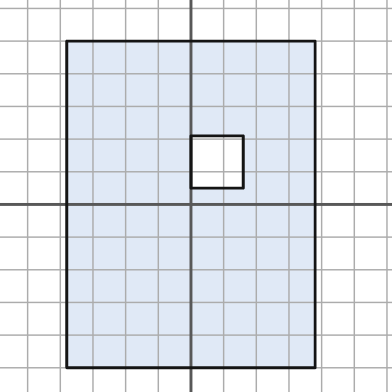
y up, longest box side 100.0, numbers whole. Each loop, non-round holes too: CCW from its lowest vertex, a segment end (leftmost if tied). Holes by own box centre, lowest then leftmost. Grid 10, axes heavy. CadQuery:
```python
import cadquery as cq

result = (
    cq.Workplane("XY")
    .moveTo(-38.0, -50.0)
    .lineTo(38.0, -50.0)
    .lineTo(38.0, 50.0)
    .lineTo(-38.0, 50.0)
    .close()
    .moveTo(0.0, 5.0)
    .lineTo(16.0, 5.0)
    .lineTo(16.0, 21.0)
    .lineTo(0.0, 21.0)
    .close()
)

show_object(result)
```